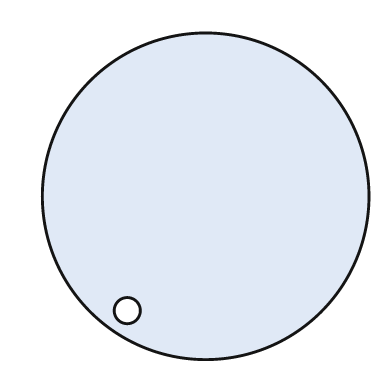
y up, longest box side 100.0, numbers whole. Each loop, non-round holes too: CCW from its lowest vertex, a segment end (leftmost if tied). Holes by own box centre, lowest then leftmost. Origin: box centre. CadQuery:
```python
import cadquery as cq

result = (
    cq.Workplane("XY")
    .moveTo(0.0, 0.0)
    .circle(50.0)
    .moveTo(-24.0, -35.0)
    .circle(4.0)
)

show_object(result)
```